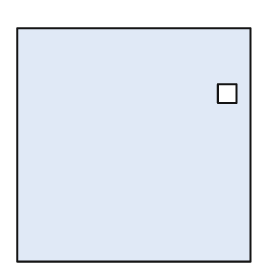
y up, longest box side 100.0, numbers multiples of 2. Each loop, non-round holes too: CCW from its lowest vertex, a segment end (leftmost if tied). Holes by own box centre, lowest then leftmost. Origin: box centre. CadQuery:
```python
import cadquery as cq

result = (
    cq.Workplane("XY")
    .moveTo(-50.0, -50.0)
    .lineTo(50.0, -50.0)
    .lineTo(50.0, 50.0)
    .lineTo(-50.0, 50.0)
    .close()
    .moveTo(36.0, 18.0)
    .lineTo(44.0, 18.0)
    .lineTo(44.0, 26.0)
    .lineTo(36.0, 26.0)
    .close()
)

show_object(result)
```